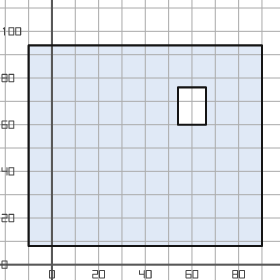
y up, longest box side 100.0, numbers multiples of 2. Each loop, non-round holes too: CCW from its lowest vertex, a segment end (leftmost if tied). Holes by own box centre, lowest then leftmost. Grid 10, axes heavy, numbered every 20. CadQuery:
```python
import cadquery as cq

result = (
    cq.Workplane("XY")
    .moveTo(-10.0, 8.0)
    .lineTo(90.0, 8.0)
    .lineTo(90.0, 94.0)
    .lineTo(-10.0, 94.0)
    .close()
    .moveTo(54.0, 60.0)
    .lineTo(66.0, 60.0)
    .lineTo(66.0, 76.0)
    .lineTo(54.0, 76.0)
    .close()
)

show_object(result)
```